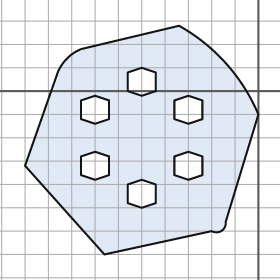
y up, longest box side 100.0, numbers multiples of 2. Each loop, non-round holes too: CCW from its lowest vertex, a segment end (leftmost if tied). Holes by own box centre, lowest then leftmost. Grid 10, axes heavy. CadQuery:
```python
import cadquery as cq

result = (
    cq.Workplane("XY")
    .moveTo(-66.0, -70.0)
    .lineTo(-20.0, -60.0)
    .threePointArc((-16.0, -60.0), (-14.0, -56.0))
    .lineTo(0.0, -10.0)
    .threePointArc((-14.0, 12.0), (-34.0, 28.0))
    .lineTo(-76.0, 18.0)
    .threePointArc((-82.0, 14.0), (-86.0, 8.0))
    .lineTo(-100.0, -32.0)
    .close()
    .moveTo(-50.0, -50.0)
    .lineTo(-44.0, -48.0)
    .lineTo(-44.0, -40.0)
    .lineTo(-50.0, -38.0)
    .lineTo(-56.0, -40.0)
    .lineTo(-56.0, -48.0)
    .close()
    .moveTo(-70.0, -38.0)
    .lineTo(-64.0, -36.0)
    .lineTo(-64.0, -28.0)
    .lineTo(-70.0, -26.0)
    .lineTo(-76.0, -28.0)
    .lineTo(-76.0, -36.0)
    .close()
    .moveTo(-30.0, -38.0)
    .lineTo(-24.0, -36.0)
    .lineTo(-24.0, -28.0)
    .lineTo(-30.0, -26.0)
    .lineTo(-36.0, -28.0)
    .lineTo(-36.0, -36.0)
    .close()
    .moveTo(-70.0, -14.0)
    .lineTo(-64.0, -12.0)
    .lineTo(-64.0, -4.0)
    .lineTo(-70.0, -2.0)
    .lineTo(-76.0, -4.0)
    .lineTo(-76.0, -12.0)
    .close()
    .moveTo(-30.0, -14.0)
    .lineTo(-24.0, -12.0)
    .lineTo(-24.0, -4.0)
    .lineTo(-30.0, -2.0)
    .lineTo(-36.0, -4.0)
    .lineTo(-36.0, -12.0)
    .close()
    .moveTo(-50.0, -2.0)
    .lineTo(-44.0, 0.0)
    .lineTo(-44.0, 8.0)
    .lineTo(-50.0, 10.0)
    .lineTo(-56.0, 8.0)
    .lineTo(-56.0, 0.0)
    .close()
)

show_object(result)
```